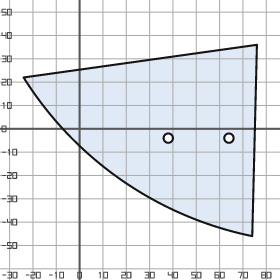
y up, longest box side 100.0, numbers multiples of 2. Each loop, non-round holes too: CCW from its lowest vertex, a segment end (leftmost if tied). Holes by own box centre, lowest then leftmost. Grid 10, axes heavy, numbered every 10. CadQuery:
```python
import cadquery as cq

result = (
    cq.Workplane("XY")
    .moveTo(74.0, -46.0)
    .lineTo(76.0, 36.0)
    .lineTo(-24.0, 22.0)
    .threePointArc((18.0, -22.0), (74.0, -46.0))
    .close()
    .moveTo(38.0, -4.0)
    .circle(2.0)
    .moveTo(64.0, -4.0)
    .circle(2.0)
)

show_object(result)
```